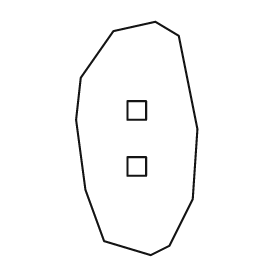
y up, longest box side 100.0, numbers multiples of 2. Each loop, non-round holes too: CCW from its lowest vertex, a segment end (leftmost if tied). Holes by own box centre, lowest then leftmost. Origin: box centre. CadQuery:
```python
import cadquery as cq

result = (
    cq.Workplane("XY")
    .moveTo(6.0, -50.0)
    .lineTo(14.0, -46.0)
    .lineTo(24.0, -26.0)
    .lineTo(26.0, 4.0)
    .lineTo(18.0, 44.0)
    .lineTo(8.0, 50.0)
    .lineTo(-10.0, 46.0)
    .lineTo(-24.0, 26.0)
    .lineTo(-26.0, 8.0)
    .lineTo(-22.0, -22.0)
    .lineTo(-14.0, -44.0)
    .close()
    .moveTo(-4.0, -16.0)
    .lineTo(4.0, -16.0)
    .lineTo(4.0, -8.0)
    .lineTo(-4.0, -8.0)
    .close()
    .moveTo(-4.0, 8.0)
    .lineTo(4.0, 8.0)
    .lineTo(4.0, 16.0)
    .lineTo(-4.0, 16.0)
    .close()
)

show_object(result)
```